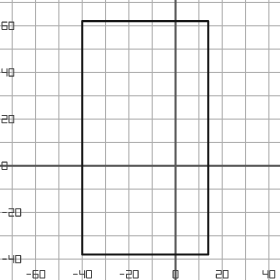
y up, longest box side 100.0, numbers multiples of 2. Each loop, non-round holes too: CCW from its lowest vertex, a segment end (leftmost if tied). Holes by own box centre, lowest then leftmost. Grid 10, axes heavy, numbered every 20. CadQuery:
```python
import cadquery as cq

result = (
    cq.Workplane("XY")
    .moveTo(-40.0, -38.0)
    .lineTo(14.0, -38.0)
    .lineTo(14.0, 62.0)
    .lineTo(-40.0, 62.0)
    .close()
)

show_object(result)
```